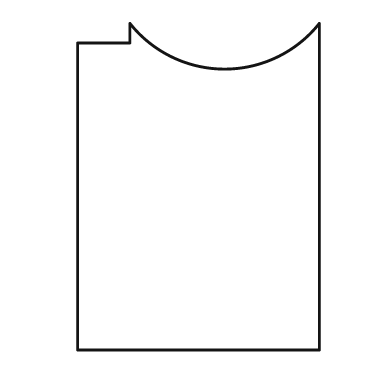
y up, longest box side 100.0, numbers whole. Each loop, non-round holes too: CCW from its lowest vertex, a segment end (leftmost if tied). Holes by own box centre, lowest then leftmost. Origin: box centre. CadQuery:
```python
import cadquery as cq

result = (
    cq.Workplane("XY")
    .moveTo(-37.0, -50.0)
    .lineTo(37.0, -50.0)
    .lineTo(37.0, 50.0)
    .threePointArc((8.0, 36.0), (-21.0, 50.0))
    .lineTo(-21.0, 44.0)
    .lineTo(-37.0, 44.0)
    .close()
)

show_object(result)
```